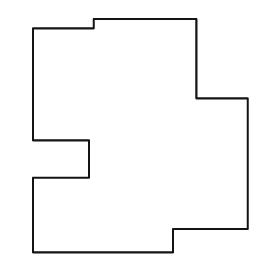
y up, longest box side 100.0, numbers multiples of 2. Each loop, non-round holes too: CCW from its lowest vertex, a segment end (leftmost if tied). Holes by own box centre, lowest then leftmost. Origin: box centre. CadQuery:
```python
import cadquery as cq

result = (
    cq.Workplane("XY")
    .moveTo(-46.0, -50.0)
    .lineTo(14.0, -50.0)
    .lineTo(14.0, -40.0)
    .lineTo(46.0, -40.0)
    .lineTo(46.0, 16.0)
    .lineTo(24.0, 16.0)
    .lineTo(24.0, 50.0)
    .lineTo(-20.0, 50.0)
    .lineTo(-20.0, 46.0)
    .lineTo(-46.0, 46.0)
    .lineTo(-46.0, -2.0)
    .lineTo(-22.0, -2.0)
    .lineTo(-22.0, -18.0)
    .lineTo(-46.0, -18.0)
    .close()
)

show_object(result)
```